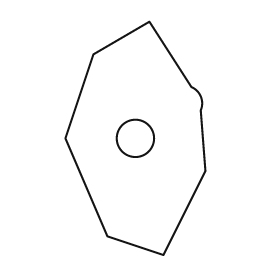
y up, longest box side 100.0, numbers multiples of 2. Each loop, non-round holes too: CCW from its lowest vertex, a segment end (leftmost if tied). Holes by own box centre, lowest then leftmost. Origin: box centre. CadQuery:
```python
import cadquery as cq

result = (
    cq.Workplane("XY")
    .moveTo(12.0, -50.0)
    .lineTo(30.0, -14.0)
    .lineTo(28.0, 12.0)
    .threePointArc((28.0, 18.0), (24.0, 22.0))
    .lineTo(6.0, 50.0)
    .lineTo(-18.0, 36.0)
    .lineTo(-30.0, 0.0)
    .lineTo(-12.0, -42.0)
    .close()
    .moveTo(0.0, 0.0)
    .circle(8.0)
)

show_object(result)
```